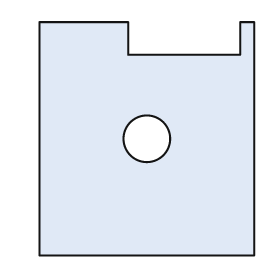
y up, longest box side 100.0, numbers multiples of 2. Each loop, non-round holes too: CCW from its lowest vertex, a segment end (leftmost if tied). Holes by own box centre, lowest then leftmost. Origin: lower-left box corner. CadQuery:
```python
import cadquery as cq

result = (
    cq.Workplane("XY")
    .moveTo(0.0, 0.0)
    .lineTo(92.0, 0.0)
    .lineTo(92.0, 100.0)
    .lineTo(86.0, 100.0)
    .lineTo(86.0, 86.0)
    .lineTo(38.0, 86.0)
    .lineTo(38.0, 100.0)
    .lineTo(0.0, 100.0)
    .close()
    .moveTo(46.0, 50.0)
    .circle(10.0)
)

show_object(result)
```